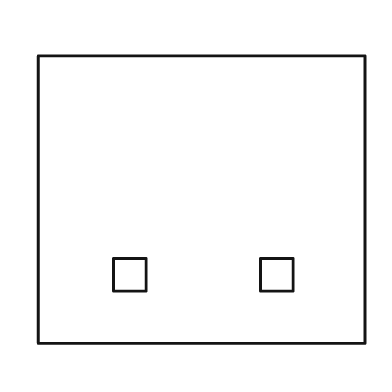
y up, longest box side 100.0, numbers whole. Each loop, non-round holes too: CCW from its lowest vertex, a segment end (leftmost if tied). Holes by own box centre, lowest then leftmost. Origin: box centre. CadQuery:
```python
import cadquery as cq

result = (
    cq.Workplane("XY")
    .moveTo(-50.0, -44.0)
    .lineTo(50.0, -44.0)
    .lineTo(50.0, 44.0)
    .lineTo(-50.0, 44.0)
    .close()
    .moveTo(-27.0, -28.0)
    .lineTo(-17.0, -28.0)
    .lineTo(-17.0, -18.0)
    .lineTo(-27.0, -18.0)
    .close()
    .moveTo(18.0, -28.0)
    .lineTo(28.0, -28.0)
    .lineTo(28.0, -18.0)
    .lineTo(18.0, -18.0)
    .close()
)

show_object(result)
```